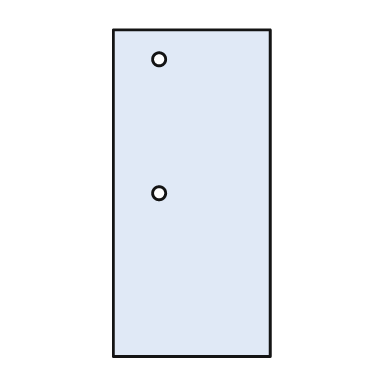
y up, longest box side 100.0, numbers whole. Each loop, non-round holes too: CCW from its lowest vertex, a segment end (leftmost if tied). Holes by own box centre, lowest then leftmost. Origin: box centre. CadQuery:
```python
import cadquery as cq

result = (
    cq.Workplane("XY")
    .moveTo(-24.0, -50.0)
    .lineTo(24.0, -50.0)
    .lineTo(24.0, 50.0)
    .lineTo(-24.0, 50.0)
    .close()
    .moveTo(-10.0, 0.0)
    .circle(2.0)
    .moveTo(-10.0, 41.0)
    .circle(2.0)
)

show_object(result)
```